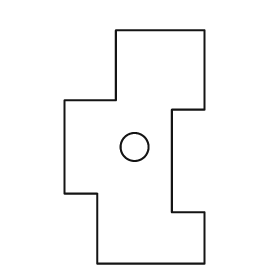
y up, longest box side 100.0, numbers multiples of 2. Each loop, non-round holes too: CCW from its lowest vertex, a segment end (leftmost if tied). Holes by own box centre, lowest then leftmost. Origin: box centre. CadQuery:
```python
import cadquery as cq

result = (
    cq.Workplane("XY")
    .moveTo(-16.0, -50.0)
    .lineTo(30.0, -50.0)
    .lineTo(30.0, -28.0)
    .lineTo(16.0, -28.0)
    .lineTo(16.0, 16.0)
    .lineTo(30.0, 16.0)
    .lineTo(30.0, 50.0)
    .lineTo(-8.0, 50.0)
    .lineTo(-8.0, 20.0)
    .lineTo(-30.0, 20.0)
    .lineTo(-30.0, -20.0)
    .lineTo(-16.0, -20.0)
    .close()
    .moveTo(0.0, 0.0)
    .circle(6.0)
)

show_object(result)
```